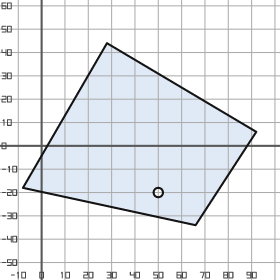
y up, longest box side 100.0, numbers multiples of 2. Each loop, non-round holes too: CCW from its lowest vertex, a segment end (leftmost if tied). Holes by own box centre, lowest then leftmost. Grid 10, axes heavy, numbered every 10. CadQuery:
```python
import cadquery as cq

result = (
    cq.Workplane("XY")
    .moveTo(66.0, -34.0)
    .lineTo(92.0, 6.0)
    .lineTo(28.0, 44.0)
    .lineTo(-8.0, -18.0)
    .close()
    .moveTo(50.0, -20.0)
    .circle(2.0)
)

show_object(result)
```